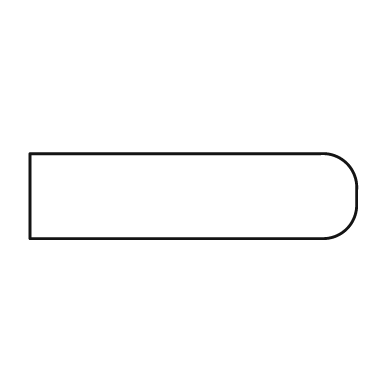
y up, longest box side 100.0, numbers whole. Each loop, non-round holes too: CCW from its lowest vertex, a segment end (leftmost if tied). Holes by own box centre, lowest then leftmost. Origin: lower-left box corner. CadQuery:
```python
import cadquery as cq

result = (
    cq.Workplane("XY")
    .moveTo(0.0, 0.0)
    .lineTo(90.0, 0.0)
    .threePointArc((97.0, 3.0), (100.0, 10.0))
    .lineTo(100.0, 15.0)
    .threePointArc((97.0, 23.0), (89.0, 26.0))
    .lineTo(0.0, 26.0)
    .close()
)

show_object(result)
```